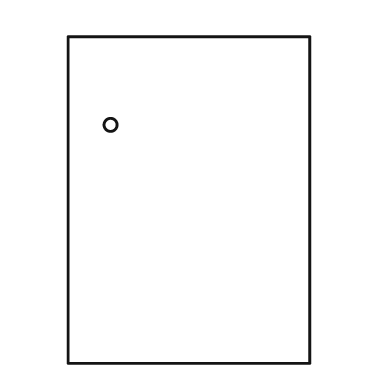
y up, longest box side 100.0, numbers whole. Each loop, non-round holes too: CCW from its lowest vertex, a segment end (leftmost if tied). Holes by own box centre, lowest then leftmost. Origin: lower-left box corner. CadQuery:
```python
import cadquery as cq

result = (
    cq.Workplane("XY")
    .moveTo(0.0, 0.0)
    .lineTo(74.0, 0.0)
    .lineTo(74.0, 100.0)
    .lineTo(0.0, 100.0)
    .close()
    .moveTo(13.0, 73.0)
    .circle(2.0)
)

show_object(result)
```